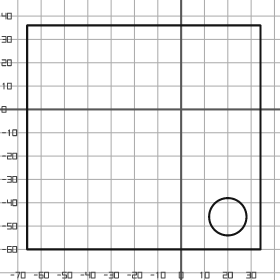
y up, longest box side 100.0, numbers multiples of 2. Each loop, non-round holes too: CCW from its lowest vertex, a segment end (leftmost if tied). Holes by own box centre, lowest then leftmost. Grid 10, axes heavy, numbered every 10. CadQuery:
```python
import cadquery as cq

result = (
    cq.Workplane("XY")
    .moveTo(-66.0, -60.0)
    .lineTo(34.0, -60.0)
    .lineTo(34.0, 36.0)
    .lineTo(-66.0, 36.0)
    .close()
    .moveTo(20.0, -46.0)
    .circle(8.0)
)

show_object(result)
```